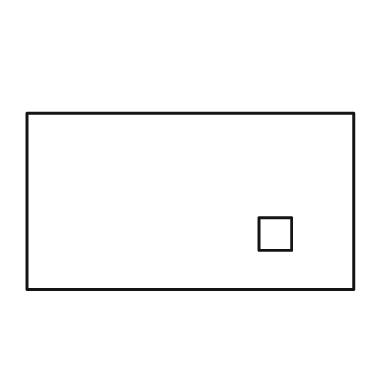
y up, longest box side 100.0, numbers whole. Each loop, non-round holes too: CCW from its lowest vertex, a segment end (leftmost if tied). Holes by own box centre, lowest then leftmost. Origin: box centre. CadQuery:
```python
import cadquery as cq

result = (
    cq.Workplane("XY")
    .moveTo(-50.0, -27.0)
    .lineTo(50.0, -27.0)
    .lineTo(50.0, 27.0)
    .lineTo(-50.0, 27.0)
    .close()
    .moveTo(21.0, -15.0)
    .lineTo(31.0, -15.0)
    .lineTo(31.0, -5.0)
    .lineTo(21.0, -5.0)
    .close()
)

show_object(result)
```